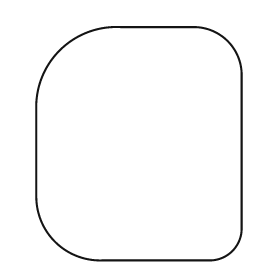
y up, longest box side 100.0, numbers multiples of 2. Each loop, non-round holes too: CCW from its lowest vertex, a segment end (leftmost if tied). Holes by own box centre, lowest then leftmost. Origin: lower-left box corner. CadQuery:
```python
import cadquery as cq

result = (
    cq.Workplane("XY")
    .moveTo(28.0, 0.0)
    .lineTo(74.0, 0.0)
    .threePointArc((84.0, 4.0), (88.0, 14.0))
    .lineTo(88.0, 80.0)
    .threePointArc((82.0, 94.0), (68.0, 100.0))
    .lineTo(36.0, 100.0)
    .threePointArc((10.0, 90.0), (0.0, 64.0))
    .lineTo(0.0, 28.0)
    .threePointArc((8.0, 8.0), (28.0, 0.0))
    .close()
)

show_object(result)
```